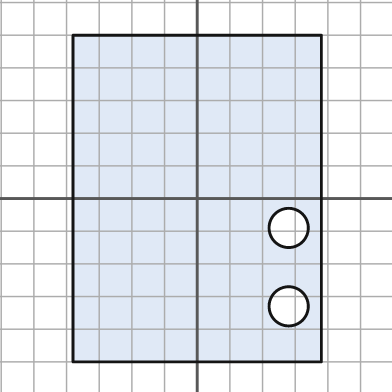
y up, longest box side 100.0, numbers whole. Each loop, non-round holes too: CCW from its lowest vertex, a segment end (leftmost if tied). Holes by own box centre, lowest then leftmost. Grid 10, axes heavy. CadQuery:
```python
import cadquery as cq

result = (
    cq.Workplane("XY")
    .moveTo(-38.0, -50.0)
    .lineTo(38.0, -50.0)
    .lineTo(38.0, 50.0)
    .lineTo(-38.0, 50.0)
    .close()
    .moveTo(28.0, -33.0)
    .circle(6.0)
    .moveTo(28.0, -9.0)
    .circle(6.0)
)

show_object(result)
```